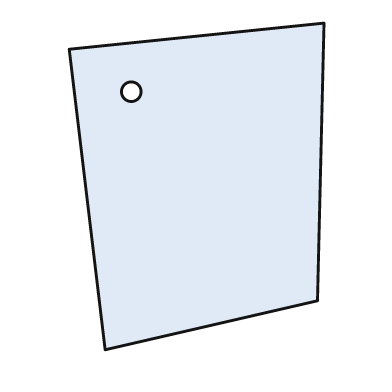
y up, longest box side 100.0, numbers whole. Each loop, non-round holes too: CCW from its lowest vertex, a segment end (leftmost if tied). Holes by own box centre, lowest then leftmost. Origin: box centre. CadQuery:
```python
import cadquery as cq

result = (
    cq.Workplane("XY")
    .moveTo(-28.0, -50.0)
    .lineTo(37.0, -35.0)
    .lineTo(39.0, 50.0)
    .lineTo(-39.0, 42.0)
    .close()
    .moveTo(-20.0, 29.0)
    .circle(3.0)
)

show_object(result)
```